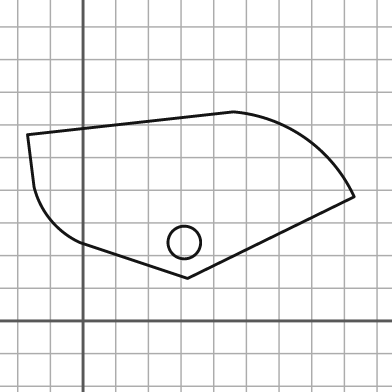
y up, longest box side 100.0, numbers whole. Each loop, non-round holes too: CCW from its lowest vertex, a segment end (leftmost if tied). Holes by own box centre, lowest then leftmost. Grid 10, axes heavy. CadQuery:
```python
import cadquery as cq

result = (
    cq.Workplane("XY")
    .moveTo(32.0, 13.0)
    .lineTo(83.0, 38.0)
    .threePointArc((68.0, 56.0), (46.0, 64.0))
    .lineTo(-17.0, 57.0)
    .lineTo(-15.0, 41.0)
    .threePointArc((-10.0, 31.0), (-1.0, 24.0))
    .close()
    .moveTo(31.0, 24.0)
    .circle(5.0)
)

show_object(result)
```